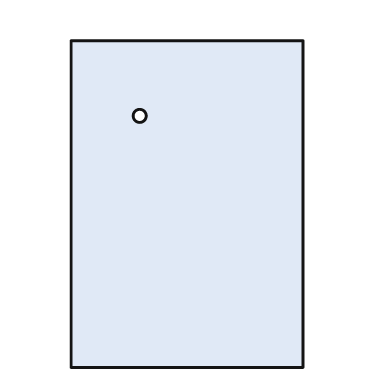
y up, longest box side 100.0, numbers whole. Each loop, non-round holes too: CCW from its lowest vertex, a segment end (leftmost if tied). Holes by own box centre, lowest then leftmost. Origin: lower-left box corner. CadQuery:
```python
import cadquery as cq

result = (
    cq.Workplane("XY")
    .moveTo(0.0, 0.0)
    .lineTo(71.0, 0.0)
    .lineTo(71.0, 100.0)
    .lineTo(0.0, 100.0)
    .close()
    .moveTo(21.0, 77.0)
    .circle(2.0)
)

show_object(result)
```